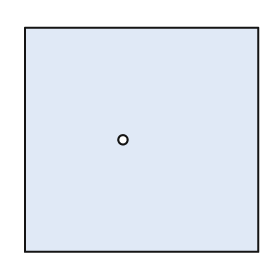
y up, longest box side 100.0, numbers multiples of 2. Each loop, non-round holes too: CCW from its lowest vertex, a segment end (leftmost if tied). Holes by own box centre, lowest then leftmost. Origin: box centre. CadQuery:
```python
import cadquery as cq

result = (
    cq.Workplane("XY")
    .moveTo(-50.0, -48.0)
    .lineTo(50.0, -48.0)
    .lineTo(50.0, 48.0)
    .lineTo(-50.0, 48.0)
    .close()
    .moveTo(-8.0, 0.0)
    .circle(2.0)
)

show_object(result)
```